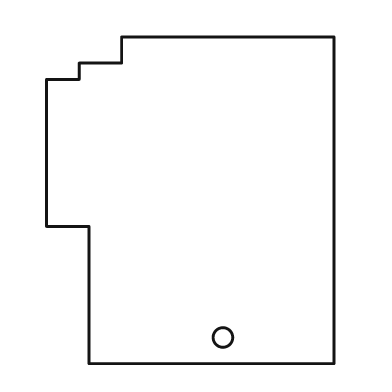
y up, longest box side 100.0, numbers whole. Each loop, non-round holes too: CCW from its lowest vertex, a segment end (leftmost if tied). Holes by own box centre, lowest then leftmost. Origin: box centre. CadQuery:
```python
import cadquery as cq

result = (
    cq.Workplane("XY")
    .moveTo(-31.0, -50.0)
    .lineTo(44.0, -50.0)
    .lineTo(44.0, 50.0)
    .lineTo(-21.0, 50.0)
    .lineTo(-21.0, 42.0)
    .lineTo(-34.0, 42.0)
    .lineTo(-34.0, 37.0)
    .lineTo(-44.0, 37.0)
    .lineTo(-44.0, -8.0)
    .lineTo(-31.0, -8.0)
    .close()
    .moveTo(10.0, -42.0)
    .circle(3.0)
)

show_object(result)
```